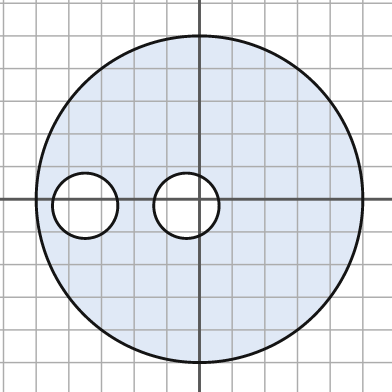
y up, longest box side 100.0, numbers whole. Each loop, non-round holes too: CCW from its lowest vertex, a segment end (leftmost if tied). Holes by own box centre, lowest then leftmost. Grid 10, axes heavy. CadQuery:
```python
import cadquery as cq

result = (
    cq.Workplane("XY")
    .moveTo(0.0, 0.0)
    .circle(50.0)
    .moveTo(-35.0, -2.0)
    .circle(10.0)
    .moveTo(-4.0, -2.0)
    .circle(10.0)
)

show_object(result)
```